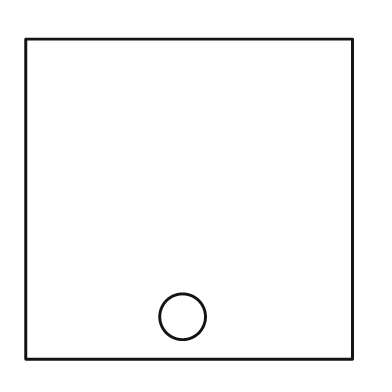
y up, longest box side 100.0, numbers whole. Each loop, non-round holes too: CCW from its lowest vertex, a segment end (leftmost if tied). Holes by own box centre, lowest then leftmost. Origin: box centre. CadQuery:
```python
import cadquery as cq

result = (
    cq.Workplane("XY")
    .moveTo(-50.0, -49.0)
    .lineTo(50.0, -49.0)
    .lineTo(50.0, 49.0)
    .lineTo(-50.0, 49.0)
    .close()
    .moveTo(-2.0, -36.0)
    .circle(7.0)
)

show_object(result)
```